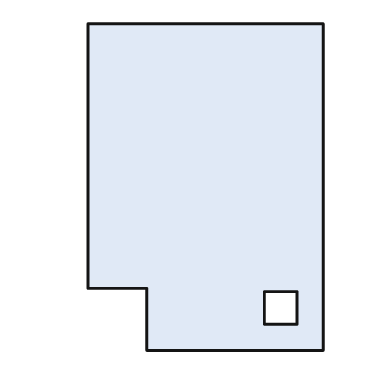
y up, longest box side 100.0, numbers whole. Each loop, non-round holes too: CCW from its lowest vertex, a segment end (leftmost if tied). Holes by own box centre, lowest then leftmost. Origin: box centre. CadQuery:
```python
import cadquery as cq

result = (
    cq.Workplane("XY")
    .moveTo(-18.0, -50.0)
    .lineTo(36.0, -50.0)
    .lineTo(36.0, 50.0)
    .lineTo(-36.0, 50.0)
    .lineTo(-36.0, -31.0)
    .lineTo(-18.0, -31.0)
    .close()
    .moveTo(18.0, -42.0)
    .lineTo(28.0, -42.0)
    .lineTo(28.0, -32.0)
    .lineTo(18.0, -32.0)
    .close()
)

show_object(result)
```